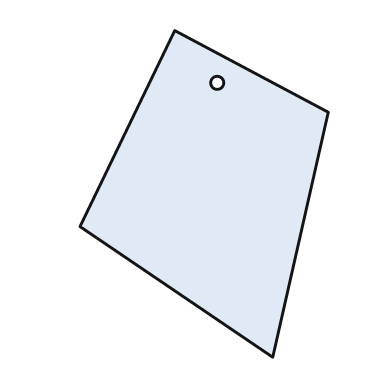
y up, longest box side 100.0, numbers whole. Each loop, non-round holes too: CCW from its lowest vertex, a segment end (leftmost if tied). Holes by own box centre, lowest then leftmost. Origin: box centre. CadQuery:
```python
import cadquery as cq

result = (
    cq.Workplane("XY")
    .moveTo(21.0, -50.0)
    .lineTo(38.0, 25.0)
    .lineTo(-9.0, 50.0)
    .lineTo(-38.0, -10.0)
    .close()
    .moveTo(4.0, 34.0)
    .circle(2.0)
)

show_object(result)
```